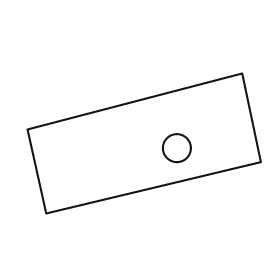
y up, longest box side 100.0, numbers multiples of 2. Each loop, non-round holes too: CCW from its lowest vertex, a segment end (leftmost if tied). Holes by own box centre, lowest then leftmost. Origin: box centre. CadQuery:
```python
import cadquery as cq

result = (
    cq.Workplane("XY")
    .moveTo(-42.0, -30.0)
    .lineTo(50.0, -8.0)
    .lineTo(42.0, 30.0)
    .lineTo(-50.0, 6.0)
    .close()
    .moveTo(14.0, -2.0)
    .circle(6.0)
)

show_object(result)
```